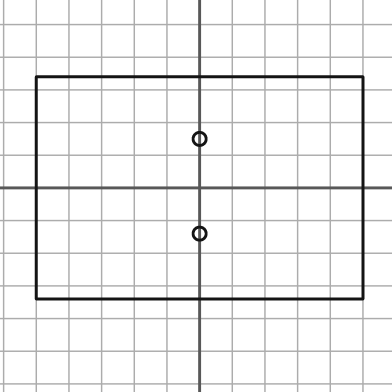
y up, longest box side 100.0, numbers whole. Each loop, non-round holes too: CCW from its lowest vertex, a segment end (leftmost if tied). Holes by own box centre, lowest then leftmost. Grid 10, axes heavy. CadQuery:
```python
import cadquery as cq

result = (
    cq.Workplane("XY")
    .moveTo(-50.0, -34.0)
    .lineTo(50.0, -34.0)
    .lineTo(50.0, 34.0)
    .lineTo(-50.0, 34.0)
    .close()
    .moveTo(0.0, -14.0)
    .circle(2.0)
    .moveTo(0.0, 15.0)
    .circle(2.0)
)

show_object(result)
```